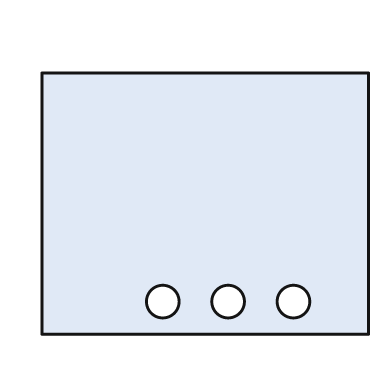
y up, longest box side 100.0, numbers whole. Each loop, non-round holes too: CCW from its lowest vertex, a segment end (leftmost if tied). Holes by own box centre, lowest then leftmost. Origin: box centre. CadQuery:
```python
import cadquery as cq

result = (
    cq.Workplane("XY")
    .moveTo(-50.0, -40.0)
    .lineTo(50.0, -40.0)
    .lineTo(50.0, 40.0)
    .lineTo(-50.0, 40.0)
    .close()
    .moveTo(-13.0, -30.0)
    .circle(5.0)
    .moveTo(7.0, -30.0)
    .circle(5.0)
    .moveTo(27.0, -30.0)
    .circle(5.0)
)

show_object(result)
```